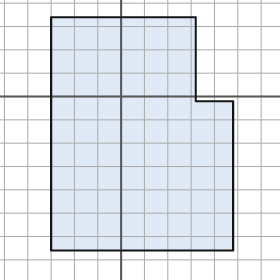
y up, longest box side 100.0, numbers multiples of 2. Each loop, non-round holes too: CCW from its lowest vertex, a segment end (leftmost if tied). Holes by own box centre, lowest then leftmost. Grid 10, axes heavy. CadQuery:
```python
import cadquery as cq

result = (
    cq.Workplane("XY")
    .moveTo(-30.0, -66.0)
    .lineTo(48.0, -66.0)
    .lineTo(48.0, -2.0)
    .lineTo(32.0, -2.0)
    .lineTo(32.0, 34.0)
    .lineTo(-30.0, 34.0)
    .close()
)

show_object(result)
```